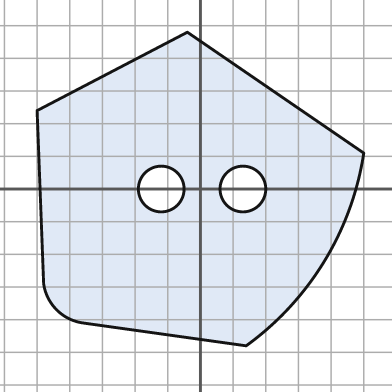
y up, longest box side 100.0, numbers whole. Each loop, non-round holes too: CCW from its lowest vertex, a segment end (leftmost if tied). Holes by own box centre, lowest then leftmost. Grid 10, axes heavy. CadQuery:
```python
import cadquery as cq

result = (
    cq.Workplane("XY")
    .moveTo(14.0, -48.0)
    .threePointArc((38.0, -22.0), (50.0, 11.0))
    .lineTo(-4.0, 48.0)
    .lineTo(-50.0, 24.0)
    .lineTo(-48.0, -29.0)
    .threePointArc((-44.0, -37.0), (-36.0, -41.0))
    .close()
    .moveTo(-12.0, 0.0)
    .circle(7.0)
    .moveTo(13.0, 0.0)
    .circle(7.0)
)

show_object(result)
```